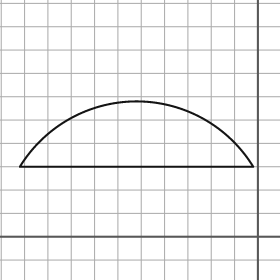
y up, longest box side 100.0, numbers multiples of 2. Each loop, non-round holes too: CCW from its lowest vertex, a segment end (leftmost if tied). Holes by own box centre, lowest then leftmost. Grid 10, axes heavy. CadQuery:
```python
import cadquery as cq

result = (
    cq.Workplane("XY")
    .moveTo(-102.0, 30.0)
    .lineTo(-2.0, 30.0)
    .threePointArc((-52.0, 58.0), (-102.0, 30.0))
    .close()
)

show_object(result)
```